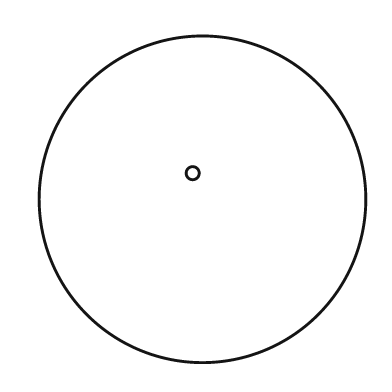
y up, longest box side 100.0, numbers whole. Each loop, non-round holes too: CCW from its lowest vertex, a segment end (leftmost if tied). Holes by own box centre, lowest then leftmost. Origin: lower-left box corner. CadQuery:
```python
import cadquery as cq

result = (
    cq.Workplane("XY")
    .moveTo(50.0, 50.0)
    .circle(50.0)
    .moveTo(47.0, 58.0)
    .circle(2.0)
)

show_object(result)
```